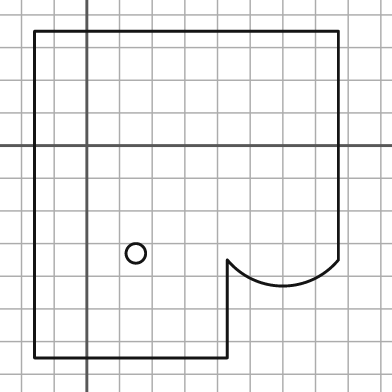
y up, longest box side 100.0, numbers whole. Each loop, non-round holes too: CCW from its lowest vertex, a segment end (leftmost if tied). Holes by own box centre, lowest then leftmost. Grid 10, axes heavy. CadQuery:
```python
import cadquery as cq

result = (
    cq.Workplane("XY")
    .moveTo(-16.0, -65.0)
    .lineTo(43.0, -65.0)
    .lineTo(43.0, -35.0)
    .threePointArc((60.0, -43.0), (77.0, -35.0))
    .lineTo(77.0, 35.0)
    .lineTo(-16.0, 35.0)
    .close()
    .moveTo(15.0, -33.0)
    .circle(3.0)
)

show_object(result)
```